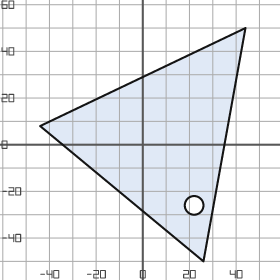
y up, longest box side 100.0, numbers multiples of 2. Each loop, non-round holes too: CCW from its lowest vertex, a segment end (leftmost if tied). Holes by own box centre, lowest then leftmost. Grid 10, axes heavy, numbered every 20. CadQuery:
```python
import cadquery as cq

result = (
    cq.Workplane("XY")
    .moveTo(26.0, -50.0)
    .lineTo(44.0, 50.0)
    .lineTo(-44.0, 8.0)
    .close()
    .moveTo(22.0, -26.0)
    .circle(4.0)
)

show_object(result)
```